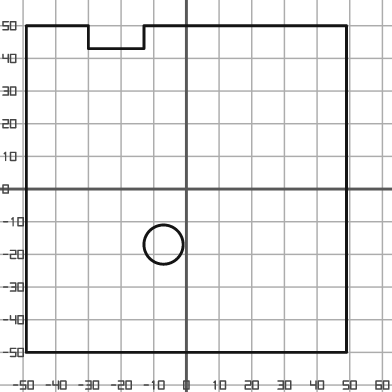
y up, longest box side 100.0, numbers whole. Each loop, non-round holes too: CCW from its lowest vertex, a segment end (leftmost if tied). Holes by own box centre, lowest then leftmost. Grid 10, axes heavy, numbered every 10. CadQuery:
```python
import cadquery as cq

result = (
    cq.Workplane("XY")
    .moveTo(-49.0, -50.0)
    .lineTo(49.0, -50.0)
    .lineTo(49.0, 50.0)
    .lineTo(-13.0, 50.0)
    .lineTo(-13.0, 43.0)
    .lineTo(-30.0, 43.0)
    .lineTo(-30.0, 50.0)
    .lineTo(-49.0, 50.0)
    .close()
    .moveTo(-7.0, -17.0)
    .circle(6.0)
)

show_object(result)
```